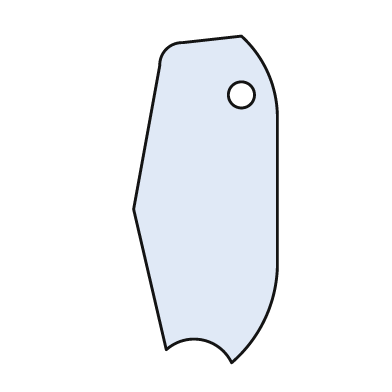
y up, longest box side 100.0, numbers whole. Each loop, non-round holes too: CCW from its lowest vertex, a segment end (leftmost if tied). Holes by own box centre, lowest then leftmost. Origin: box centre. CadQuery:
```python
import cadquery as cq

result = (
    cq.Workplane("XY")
    .moveTo(8.0, -50.0)
    .threePointArc((18.0, -37.0), (22.0, -21.0))
    .lineTo(22.0, 26.0)
    .threePointArc((19.0, 39.0), (11.0, 50.0))
    .lineTo(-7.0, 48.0)
    .threePointArc((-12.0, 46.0), (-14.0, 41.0))
    .lineTo(-22.0, -3.0)
    .lineTo(-12.0, -46.0)
    .threePointArc((-1.0, -43.0), (8.0, -50.0))
    .close()
    .moveTo(11.0, 32.0)
    .circle(4.0)
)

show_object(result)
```